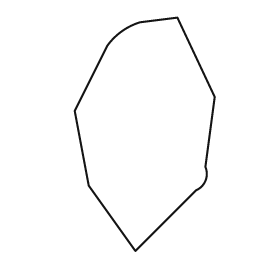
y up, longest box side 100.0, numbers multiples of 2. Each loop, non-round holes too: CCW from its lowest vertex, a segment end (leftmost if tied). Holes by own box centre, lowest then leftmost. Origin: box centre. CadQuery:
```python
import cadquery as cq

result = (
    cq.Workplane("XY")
    .moveTo(-4.0, -50.0)
    .lineTo(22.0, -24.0)
    .threePointArc((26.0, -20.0), (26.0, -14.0))
    .lineTo(30.0, 16.0)
    .lineTo(14.0, 50.0)
    .lineTo(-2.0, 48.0)
    .threePointArc((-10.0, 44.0), (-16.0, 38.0))
    .lineTo(-30.0, 10.0)
    .lineTo(-24.0, -22.0)
    .close()
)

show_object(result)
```